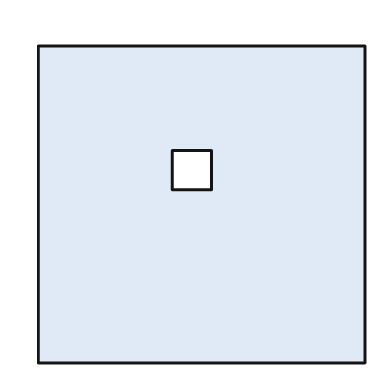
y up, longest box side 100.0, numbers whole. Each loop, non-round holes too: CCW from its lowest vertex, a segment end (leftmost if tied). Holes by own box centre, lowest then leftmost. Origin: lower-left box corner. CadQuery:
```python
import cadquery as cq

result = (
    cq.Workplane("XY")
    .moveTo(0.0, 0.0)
    .lineTo(100.0, 0.0)
    .lineTo(100.0, 97.0)
    .lineTo(0.0, 97.0)
    .close()
    .moveTo(41.0, 53.0)
    .lineTo(53.0, 53.0)
    .lineTo(53.0, 65.0)
    .lineTo(41.0, 65.0)
    .close()
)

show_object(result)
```